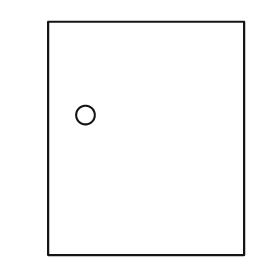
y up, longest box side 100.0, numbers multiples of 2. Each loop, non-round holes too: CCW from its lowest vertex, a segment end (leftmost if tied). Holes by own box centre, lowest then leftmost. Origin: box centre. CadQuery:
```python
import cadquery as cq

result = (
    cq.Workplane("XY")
    .moveTo(-42.0, -50.0)
    .lineTo(42.0, -50.0)
    .lineTo(42.0, 50.0)
    .lineTo(-42.0, 50.0)
    .close()
    .moveTo(-26.0, 10.0)
    .circle(4.0)
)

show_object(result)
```